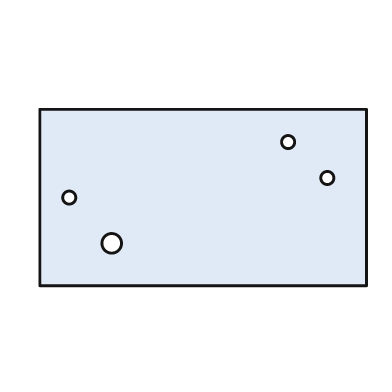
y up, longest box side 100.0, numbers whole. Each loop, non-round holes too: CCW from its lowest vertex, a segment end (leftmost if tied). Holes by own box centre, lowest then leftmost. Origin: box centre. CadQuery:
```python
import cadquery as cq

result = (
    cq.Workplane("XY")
    .moveTo(-50.0, -27.0)
    .lineTo(50.0, -27.0)
    .lineTo(50.0, 27.0)
    .lineTo(-50.0, 27.0)
    .close()
    .moveTo(-28.0, -14.0)
    .circle(3.0)
    .moveTo(-41.0, 0.0)
    .circle(2.0)
    .moveTo(38.0, 6.0)
    .circle(2.0)
    .moveTo(26.0, 17.0)
    .circle(2.0)
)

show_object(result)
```